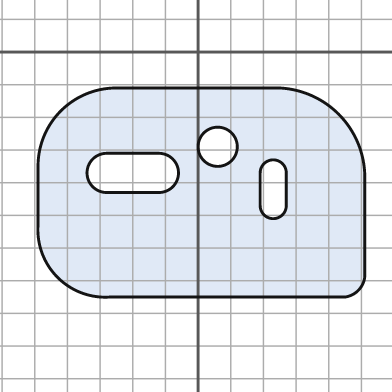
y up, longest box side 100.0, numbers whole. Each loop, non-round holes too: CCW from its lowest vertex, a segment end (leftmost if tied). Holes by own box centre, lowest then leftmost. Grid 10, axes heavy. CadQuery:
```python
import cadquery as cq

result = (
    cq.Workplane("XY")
    .moveTo(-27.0, -75.0)
    .lineTo(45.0, -75.0)
    .threePointArc((49.0, -73.0), (51.0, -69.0))
    .lineTo(51.0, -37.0)
    .threePointArc((43.0, -19.0), (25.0, -11.0))
    .lineTo(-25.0, -11.0)
    .threePointArc((-42.0, -18.0), (-49.0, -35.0))
    .lineTo(-49.0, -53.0)
    .threePointArc((-43.0, -69.0), (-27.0, -75.0))
    .close()
    .moveTo(19.0, -47.0)
    .threePointArc((23.0, -51.0), (27.0, -47.0))
    .lineTo(27.0, -37.0)
    .threePointArc((23.0, -33.0), (19.0, -37.0))
    .close()
    .moveTo(-28.0, -43.0)
    .lineTo(-12.0, -43.0)
    .threePointArc((-6.0, -37.0), (-12.0, -31.0))
    .lineTo(-28.0, -31.0)
    .threePointArc((-34.0, -37.0), (-28.0, -43.0))
    .close()
    .moveTo(6.0, -29.0)
    .circle(6.0)
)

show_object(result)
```